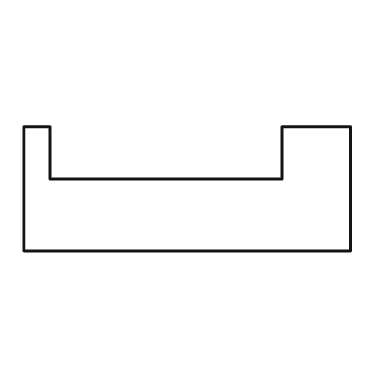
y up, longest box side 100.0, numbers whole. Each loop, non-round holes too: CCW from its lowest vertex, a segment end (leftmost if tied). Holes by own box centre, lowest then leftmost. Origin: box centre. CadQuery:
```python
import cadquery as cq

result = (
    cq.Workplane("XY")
    .moveTo(-50.0, -19.0)
    .lineTo(50.0, -19.0)
    .lineTo(50.0, 19.0)
    .lineTo(29.0, 19.0)
    .lineTo(29.0, 3.0)
    .lineTo(-42.0, 3.0)
    .lineTo(-42.0, 19.0)
    .lineTo(-50.0, 19.0)
    .close()
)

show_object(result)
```